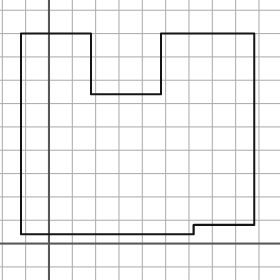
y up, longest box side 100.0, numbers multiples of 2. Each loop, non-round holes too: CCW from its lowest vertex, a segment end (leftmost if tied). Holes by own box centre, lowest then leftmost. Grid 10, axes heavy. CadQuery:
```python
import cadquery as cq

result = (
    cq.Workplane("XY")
    .moveTo(-12.0, 4.0)
    .lineTo(62.0, 4.0)
    .lineTo(62.0, 8.0)
    .lineTo(88.0, 8.0)
    .lineTo(88.0, 90.0)
    .lineTo(48.0, 90.0)
    .lineTo(48.0, 64.0)
    .lineTo(18.0, 64.0)
    .lineTo(18.0, 90.0)
    .lineTo(-12.0, 90.0)
    .close()
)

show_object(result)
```